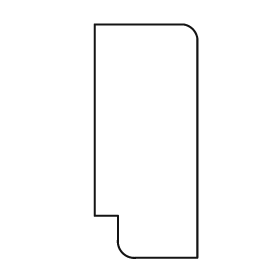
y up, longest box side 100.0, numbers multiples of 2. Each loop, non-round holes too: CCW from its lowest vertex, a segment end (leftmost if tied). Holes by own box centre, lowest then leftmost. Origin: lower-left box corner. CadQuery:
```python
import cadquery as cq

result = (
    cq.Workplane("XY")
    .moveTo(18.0, 0.0)
    .lineTo(44.0, 0.0)
    .lineTo(44.0, 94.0)
    .threePointArc((42.0, 98.0), (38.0, 100.0))
    .lineTo(0.0, 100.0)
    .lineTo(0.0, 18.0)
    .lineTo(10.0, 18.0)
    .lineTo(10.0, 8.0)
    .threePointArc((12.0, 2.0), (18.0, 0.0))
    .close()
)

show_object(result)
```